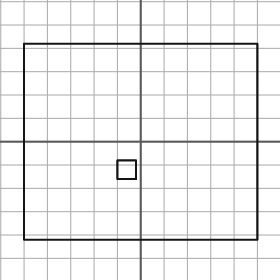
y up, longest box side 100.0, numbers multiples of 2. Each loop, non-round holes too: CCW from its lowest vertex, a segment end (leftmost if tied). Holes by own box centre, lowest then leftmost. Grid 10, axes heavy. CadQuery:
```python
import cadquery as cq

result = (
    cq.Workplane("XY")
    .moveTo(-50.0, -42.0)
    .lineTo(50.0, -42.0)
    .lineTo(50.0, 42.0)
    .lineTo(-50.0, 42.0)
    .close()
    .moveTo(-10.0, -16.0)
    .lineTo(-2.0, -16.0)
    .lineTo(-2.0, -8.0)
    .lineTo(-10.0, -8.0)
    .close()
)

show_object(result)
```